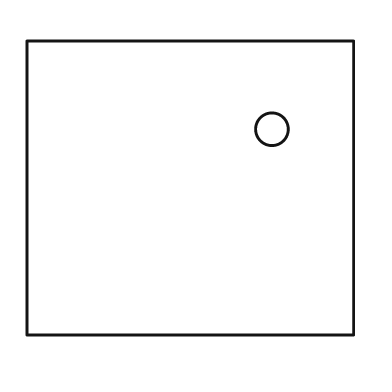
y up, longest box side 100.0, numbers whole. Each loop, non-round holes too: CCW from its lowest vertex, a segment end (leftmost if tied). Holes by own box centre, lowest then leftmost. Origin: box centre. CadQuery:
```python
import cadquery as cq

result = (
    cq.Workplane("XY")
    .moveTo(-50.0, -45.0)
    .lineTo(50.0, -45.0)
    .lineTo(50.0, 45.0)
    .lineTo(-50.0, 45.0)
    .close()
    .moveTo(25.0, 18.0)
    .circle(5.0)
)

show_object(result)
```